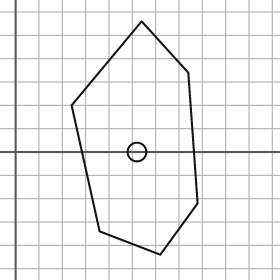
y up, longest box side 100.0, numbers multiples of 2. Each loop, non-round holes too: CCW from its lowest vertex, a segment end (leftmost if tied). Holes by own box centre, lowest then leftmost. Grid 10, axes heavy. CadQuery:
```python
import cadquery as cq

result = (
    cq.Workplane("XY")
    .moveTo(62.0, -44.0)
    .lineTo(78.0, -22.0)
    .lineTo(74.0, 34.0)
    .lineTo(54.0, 56.0)
    .lineTo(24.0, 20.0)
    .lineTo(36.0, -34.0)
    .close()
    .moveTo(52.0, 0.0)
    .circle(4.0)
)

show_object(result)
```